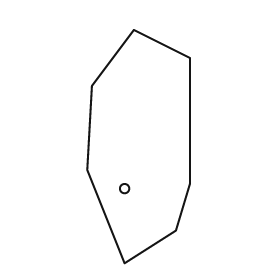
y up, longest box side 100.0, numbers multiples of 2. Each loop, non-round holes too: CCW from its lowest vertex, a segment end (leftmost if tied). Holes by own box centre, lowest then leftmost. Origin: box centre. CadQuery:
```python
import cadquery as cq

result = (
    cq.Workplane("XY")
    .moveTo(-6.0, -50.0)
    .lineTo(16.0, -36.0)
    .lineTo(22.0, -16.0)
    .lineTo(22.0, 38.0)
    .lineTo(-2.0, 50.0)
    .lineTo(-20.0, 26.0)
    .lineTo(-22.0, -10.0)
    .close()
    .moveTo(-6.0, -18.0)
    .circle(2.0)
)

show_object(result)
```